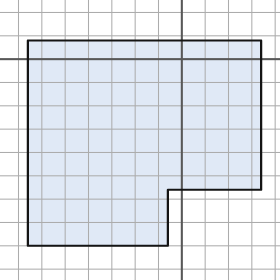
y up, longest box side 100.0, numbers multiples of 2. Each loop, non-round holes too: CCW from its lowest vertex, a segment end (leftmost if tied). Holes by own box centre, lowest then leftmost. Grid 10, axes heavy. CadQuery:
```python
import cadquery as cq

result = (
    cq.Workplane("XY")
    .moveTo(-66.0, -80.0)
    .lineTo(-6.0, -80.0)
    .lineTo(-6.0, -56.0)
    .lineTo(34.0, -56.0)
    .lineTo(34.0, 8.0)
    .lineTo(-66.0, 8.0)
    .close()
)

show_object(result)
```